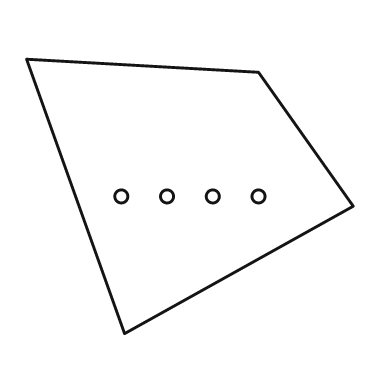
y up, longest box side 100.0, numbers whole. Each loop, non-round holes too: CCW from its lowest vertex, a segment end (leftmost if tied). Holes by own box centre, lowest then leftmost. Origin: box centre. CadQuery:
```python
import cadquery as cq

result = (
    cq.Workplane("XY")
    .moveTo(-20.0, -42.0)
    .lineTo(50.0, -3.0)
    .lineTo(21.0, 38.0)
    .lineTo(-50.0, 42.0)
    .close()
    .moveTo(-21.0, 0.0)
    .circle(2.0)
    .moveTo(-7.0, 0.0)
    .circle(2.0)
    .moveTo(7.0, 0.0)
    .circle(2.0)
    .moveTo(21.0, 0.0)
    .circle(2.0)
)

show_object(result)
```